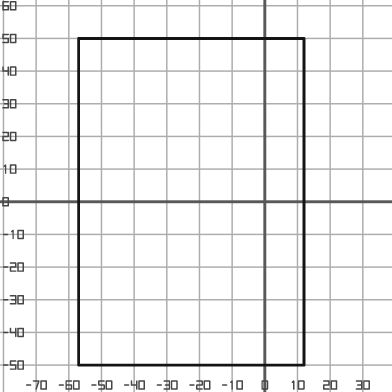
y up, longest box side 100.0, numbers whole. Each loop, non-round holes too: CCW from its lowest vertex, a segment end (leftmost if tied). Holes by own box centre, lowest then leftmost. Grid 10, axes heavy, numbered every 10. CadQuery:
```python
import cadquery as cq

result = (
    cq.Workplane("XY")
    .moveTo(-57.0, -50.0)
    .lineTo(12.0, -50.0)
    .lineTo(12.0, 50.0)
    .lineTo(-57.0, 50.0)
    .close()
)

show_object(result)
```